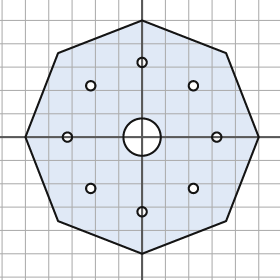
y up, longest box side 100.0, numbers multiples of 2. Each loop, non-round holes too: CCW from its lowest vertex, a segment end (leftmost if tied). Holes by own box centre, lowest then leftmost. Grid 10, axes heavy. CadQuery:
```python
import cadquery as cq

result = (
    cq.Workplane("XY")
    .moveTo(0.0, -50.0)
    .lineTo(36.0, -36.0)
    .lineTo(50.0, 0.0)
    .lineTo(36.0, 36.0)
    .lineTo(0.0, 50.0)
    .lineTo(-36.0, 36.0)
    .lineTo(-50.0, 0.0)
    .lineTo(-36.0, -36.0)
    .close()
    .moveTo(0.0, -32.0)
    .circle(2.0)
    .moveTo(-22.0, -22.0)
    .circle(2.0)
    .moveTo(22.0, -22.0)
    .circle(2.0)
    .moveTo(-32.0, 0.0)
    .circle(2.0)
    .moveTo(0.0, 0.0)
    .circle(8.0)
    .moveTo(32.0, 0.0)
    .circle(2.0)
    .moveTo(-22.0, 22.0)
    .circle(2.0)
    .moveTo(22.0, 22.0)
    .circle(2.0)
    .moveTo(0.0, 32.0)
    .circle(2.0)
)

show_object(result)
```